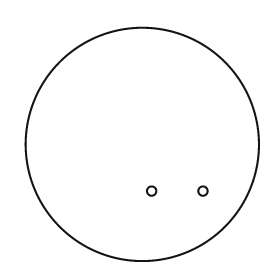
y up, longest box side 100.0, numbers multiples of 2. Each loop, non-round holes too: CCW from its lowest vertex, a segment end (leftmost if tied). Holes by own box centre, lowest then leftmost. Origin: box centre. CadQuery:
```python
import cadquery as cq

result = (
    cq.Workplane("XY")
    .moveTo(0.0, 0.0)
    .circle(50.0)
    .moveTo(4.0, -20.0)
    .circle(2.0)
    .moveTo(26.0, -20.0)
    .circle(2.0)
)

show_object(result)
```